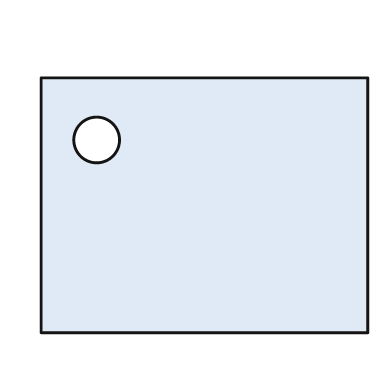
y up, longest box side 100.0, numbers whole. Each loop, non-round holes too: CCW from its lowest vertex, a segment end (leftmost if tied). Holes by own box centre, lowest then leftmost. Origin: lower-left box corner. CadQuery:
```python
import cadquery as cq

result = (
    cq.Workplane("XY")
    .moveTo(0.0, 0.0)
    .lineTo(100.0, 0.0)
    .lineTo(100.0, 78.0)
    .lineTo(0.0, 78.0)
    .close()
    .moveTo(17.0, 59.0)
    .circle(7.0)
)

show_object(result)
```